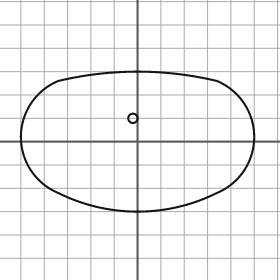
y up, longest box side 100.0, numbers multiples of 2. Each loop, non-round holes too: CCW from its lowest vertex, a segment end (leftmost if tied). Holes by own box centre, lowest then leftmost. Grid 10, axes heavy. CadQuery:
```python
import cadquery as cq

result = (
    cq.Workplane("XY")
    .moveTo(-34.0, -22.0)
    .threePointArc((0.0, -30.0), (34.0, -22.0))
    .threePointArc((50.0, 2.0), (34.0, 26.0))
    .threePointArc((0.0, 30.0), (-34.0, 26.0))
    .threePointArc((-50.0, 2.0), (-34.0, -22.0))
    .close()
    .moveTo(-2.0, 10.0)
    .circle(2.0)
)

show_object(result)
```